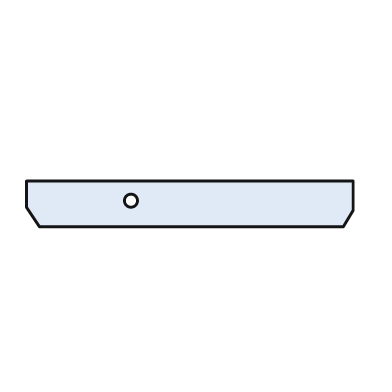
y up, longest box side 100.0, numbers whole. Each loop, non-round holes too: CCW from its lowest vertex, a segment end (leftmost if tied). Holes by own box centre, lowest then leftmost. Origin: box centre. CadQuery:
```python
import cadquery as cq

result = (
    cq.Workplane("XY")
    .moveTo(-46.0, -7.0)
    .lineTo(47.0, -7.0)
    .lineTo(50.0, -2.0)
    .lineTo(50.0, 7.0)
    .lineTo(-50.0, 7.0)
    .lineTo(-50.0, -1.0)
    .close()
    .moveTo(-18.0, 1.0)
    .circle(2.0)
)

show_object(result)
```